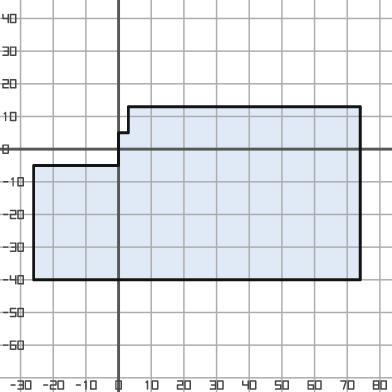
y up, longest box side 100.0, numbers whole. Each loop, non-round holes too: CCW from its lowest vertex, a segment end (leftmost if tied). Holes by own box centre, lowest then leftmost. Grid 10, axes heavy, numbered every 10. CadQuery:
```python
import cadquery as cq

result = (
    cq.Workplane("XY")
    .moveTo(-26.0, -40.0)
    .lineTo(74.0, -40.0)
    .lineTo(74.0, 13.0)
    .lineTo(3.0, 13.0)
    .lineTo(3.0, 5.0)
    .lineTo(0.0, 5.0)
    .lineTo(0.0, -5.0)
    .lineTo(-26.0, -5.0)
    .close()
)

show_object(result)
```